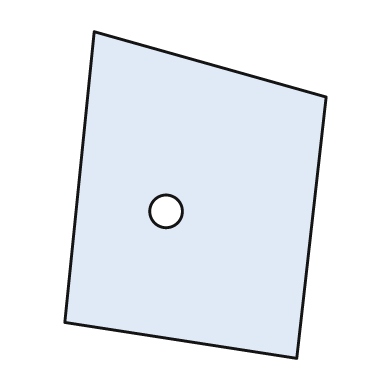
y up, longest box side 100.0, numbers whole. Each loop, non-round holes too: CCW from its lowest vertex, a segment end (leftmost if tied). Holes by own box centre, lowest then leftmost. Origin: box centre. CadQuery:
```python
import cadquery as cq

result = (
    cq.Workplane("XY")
    .moveTo(31.0, -50.0)
    .lineTo(40.0, 30.0)
    .lineTo(-31.0, 50.0)
    .lineTo(-40.0, -39.0)
    .close()
    .moveTo(-9.0, -5.0)
    .circle(5.0)
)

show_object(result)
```